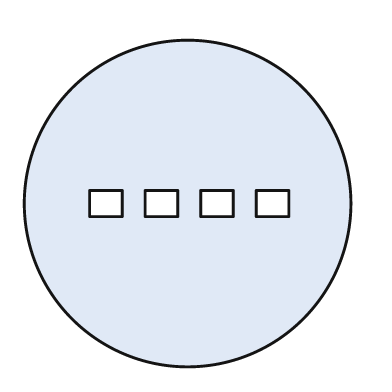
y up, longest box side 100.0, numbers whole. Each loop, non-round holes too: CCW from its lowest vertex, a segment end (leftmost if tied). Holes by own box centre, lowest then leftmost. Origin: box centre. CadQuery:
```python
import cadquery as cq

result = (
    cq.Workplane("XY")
    .moveTo(0.0, 0.0)
    .circle(50.0)
    .moveTo(-30.0, -4.0)
    .lineTo(-20.0, -4.0)
    .lineTo(-20.0, 4.0)
    .lineTo(-30.0, 4.0)
    .close()
    .moveTo(-13.0, -4.0)
    .lineTo(-3.0, -4.0)
    .lineTo(-3.0, 4.0)
    .lineTo(-13.0, 4.0)
    .close()
    .moveTo(4.0, -4.0)
    .lineTo(14.0, -4.0)
    .lineTo(14.0, 4.0)
    .lineTo(4.0, 4.0)
    .close()
    .moveTo(21.0, -4.0)
    .lineTo(31.0, -4.0)
    .lineTo(31.0, 4.0)
    .lineTo(21.0, 4.0)
    .close()
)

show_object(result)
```